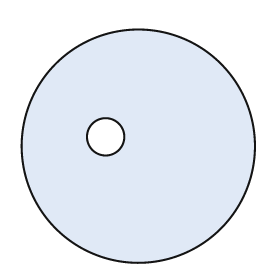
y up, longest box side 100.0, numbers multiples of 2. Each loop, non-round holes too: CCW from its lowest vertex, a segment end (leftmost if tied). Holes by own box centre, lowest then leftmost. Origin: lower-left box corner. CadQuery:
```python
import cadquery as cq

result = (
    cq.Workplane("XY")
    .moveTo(50.0, 50.0)
    .circle(50.0)
    .moveTo(36.0, 54.0)
    .circle(8.0)
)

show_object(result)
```